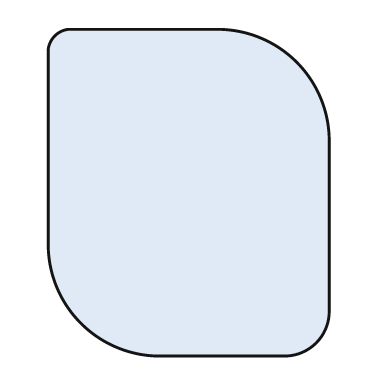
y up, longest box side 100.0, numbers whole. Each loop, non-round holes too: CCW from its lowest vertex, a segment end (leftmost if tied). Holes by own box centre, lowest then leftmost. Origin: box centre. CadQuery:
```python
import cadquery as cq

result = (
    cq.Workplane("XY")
    .moveTo(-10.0, -50.0)
    .lineTo(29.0, -50.0)
    .threePointArc((39.0, -46.0), (43.0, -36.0))
    .lineTo(43.0, 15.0)
    .threePointArc((33.0, 40.0), (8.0, 50.0))
    .lineTo(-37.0, 50.0)
    .threePointArc((-41.0, 48.0), (-43.0, 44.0))
    .lineTo(-43.0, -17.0)
    .threePointArc((-33.0, -40.0), (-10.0, -50.0))
    .close()
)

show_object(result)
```